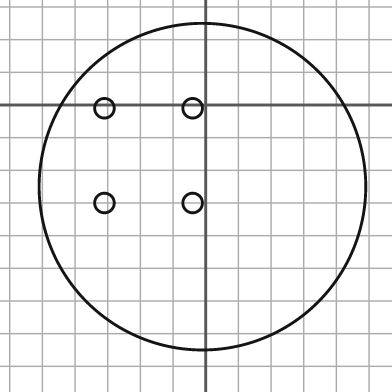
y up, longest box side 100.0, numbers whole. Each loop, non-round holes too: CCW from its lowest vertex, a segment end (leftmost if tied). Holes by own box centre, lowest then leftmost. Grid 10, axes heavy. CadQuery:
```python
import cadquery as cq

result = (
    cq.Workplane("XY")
    .moveTo(-1.0, -25.0)
    .circle(50.0)
    .moveTo(-31.0, -30.0)
    .circle(3.0)
    .moveTo(-4.0, -30.0)
    .circle(3.0)
    .moveTo(-31.0, -1.0)
    .circle(3.0)
    .moveTo(-4.0, -1.0)
    .circle(3.0)
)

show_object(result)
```